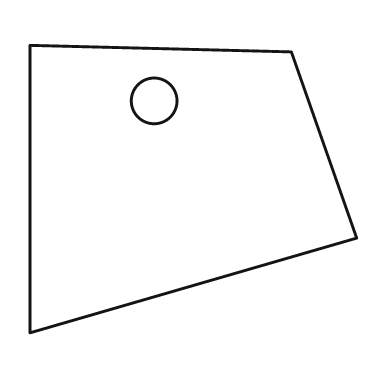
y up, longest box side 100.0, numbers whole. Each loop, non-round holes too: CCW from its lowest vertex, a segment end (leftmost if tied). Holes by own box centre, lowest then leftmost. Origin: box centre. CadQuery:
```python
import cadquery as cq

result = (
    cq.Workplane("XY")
    .moveTo(-50.0, -44.0)
    .lineTo(50.0, -15.0)
    .lineTo(30.0, 42.0)
    .lineTo(-50.0, 44.0)
    .close()
    .moveTo(-12.0, 27.0)
    .circle(7.0)
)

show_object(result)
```